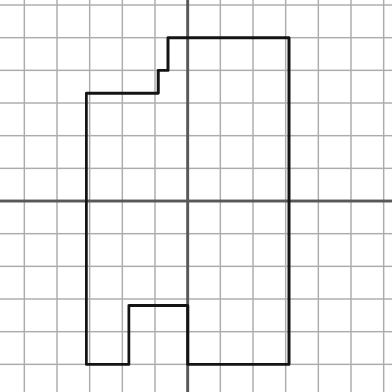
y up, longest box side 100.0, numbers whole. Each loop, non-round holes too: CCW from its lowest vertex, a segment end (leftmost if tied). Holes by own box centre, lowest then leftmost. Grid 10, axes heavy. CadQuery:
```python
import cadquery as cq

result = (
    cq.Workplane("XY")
    .moveTo(-31.0, -50.0)
    .lineTo(-18.0, -50.0)
    .lineTo(-18.0, -32.0)
    .lineTo(0.0, -32.0)
    .lineTo(0.0, -50.0)
    .lineTo(31.0, -50.0)
    .lineTo(31.0, 50.0)
    .lineTo(-6.0, 50.0)
    .lineTo(-6.0, 40.0)
    .lineTo(-9.0, 40.0)
    .lineTo(-9.0, 33.0)
    .lineTo(-31.0, 33.0)
    .close()
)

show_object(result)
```